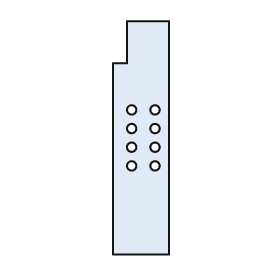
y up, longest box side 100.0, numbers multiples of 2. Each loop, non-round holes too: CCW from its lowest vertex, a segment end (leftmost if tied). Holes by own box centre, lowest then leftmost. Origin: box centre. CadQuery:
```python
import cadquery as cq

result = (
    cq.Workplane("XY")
    .moveTo(-12.0, -50.0)
    .lineTo(12.0, -50.0)
    .lineTo(12.0, 50.0)
    .lineTo(-6.0, 50.0)
    .lineTo(-6.0, 32.0)
    .lineTo(-12.0, 32.0)
    .close()
    .moveTo(-4.0, -12.0)
    .circle(2.0)
    .moveTo(6.0, -12.0)
    .circle(2.0)
    .moveTo(-4.0, -4.0)
    .circle(2.0)
    .moveTo(6.0, -4.0)
    .circle(2.0)
    .moveTo(-4.0, 4.0)
    .circle(2.0)
    .moveTo(6.0, 4.0)
    .circle(2.0)
    .moveTo(-4.0, 12.0)
    .circle(2.0)
    .moveTo(6.0, 12.0)
    .circle(2.0)
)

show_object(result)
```